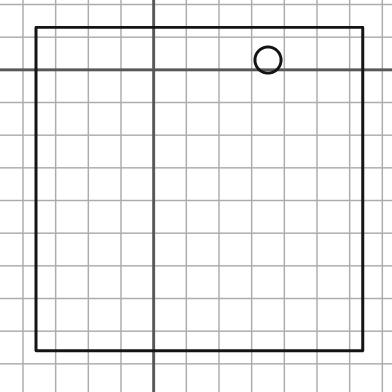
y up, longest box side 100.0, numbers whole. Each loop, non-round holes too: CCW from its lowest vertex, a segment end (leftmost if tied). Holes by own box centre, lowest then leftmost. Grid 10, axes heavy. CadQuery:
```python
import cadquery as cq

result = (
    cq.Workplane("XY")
    .moveTo(-36.0, -86.0)
    .lineTo(64.0, -86.0)
    .lineTo(64.0, 13.0)
    .lineTo(-36.0, 13.0)
    .close()
    .moveTo(35.0, 3.0)
    .circle(4.0)
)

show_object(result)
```